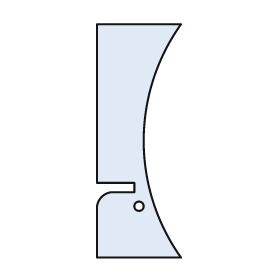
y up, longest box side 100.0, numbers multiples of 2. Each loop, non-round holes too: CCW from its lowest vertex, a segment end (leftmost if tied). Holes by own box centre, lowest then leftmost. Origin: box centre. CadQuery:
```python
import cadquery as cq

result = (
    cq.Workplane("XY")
    .moveTo(-18.0, -50.0)
    .lineTo(18.0, -50.0)
    .threePointArc((2.0, 0.0), (18.0, 50.0))
    .lineTo(-18.0, 50.0)
    .lineTo(-18.0, -18.0)
    .lineTo(-2.0, -18.0)
    .lineTo(-2.0, -22.0)
    .lineTo(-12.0, -22.0)
    .threePointArc((-16.0, -24.0), (-18.0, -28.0))
    .close()
    .moveTo(0.0, -28.0)
    .circle(2.0)
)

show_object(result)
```